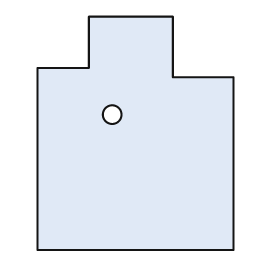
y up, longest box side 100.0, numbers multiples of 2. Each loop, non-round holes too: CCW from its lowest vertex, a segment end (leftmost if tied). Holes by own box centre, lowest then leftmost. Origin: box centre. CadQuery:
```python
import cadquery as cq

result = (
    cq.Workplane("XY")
    .moveTo(-42.0, -50.0)
    .lineTo(42.0, -50.0)
    .lineTo(42.0, 24.0)
    .lineTo(16.0, 24.0)
    .lineTo(16.0, 50.0)
    .lineTo(-20.0, 50.0)
    .lineTo(-20.0, 28.0)
    .lineTo(-42.0, 28.0)
    .close()
    .moveTo(-10.0, 8.0)
    .circle(4.0)
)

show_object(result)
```